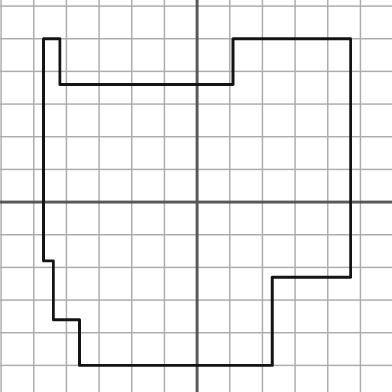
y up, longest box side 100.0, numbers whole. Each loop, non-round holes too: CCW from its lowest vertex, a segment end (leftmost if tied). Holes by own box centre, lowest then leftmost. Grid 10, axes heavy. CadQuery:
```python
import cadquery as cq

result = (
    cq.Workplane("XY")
    .moveTo(-36.0, -50.0)
    .lineTo(23.0, -50.0)
    .lineTo(23.0, -23.0)
    .lineTo(47.0, -23.0)
    .lineTo(47.0, 50.0)
    .lineTo(11.0, 50.0)
    .lineTo(11.0, 36.0)
    .lineTo(-42.0, 36.0)
    .lineTo(-42.0, 50.0)
    .lineTo(-47.0, 50.0)
    .lineTo(-47.0, -18.0)
    .lineTo(-44.0, -18.0)
    .lineTo(-44.0, -36.0)
    .lineTo(-36.0, -36.0)
    .close()
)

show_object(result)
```